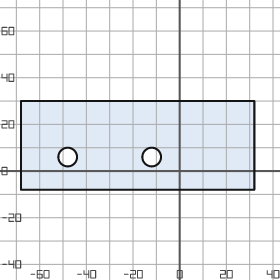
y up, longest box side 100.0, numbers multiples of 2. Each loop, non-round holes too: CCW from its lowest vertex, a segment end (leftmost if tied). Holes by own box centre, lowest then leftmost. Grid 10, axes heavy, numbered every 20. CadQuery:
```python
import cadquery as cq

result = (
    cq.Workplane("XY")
    .moveTo(-68.0, -8.0)
    .lineTo(32.0, -8.0)
    .lineTo(32.0, 30.0)
    .lineTo(-68.0, 30.0)
    .close()
    .moveTo(-48.0, 6.0)
    .circle(4.0)
    .moveTo(-12.0, 6.0)
    .circle(4.0)
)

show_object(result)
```